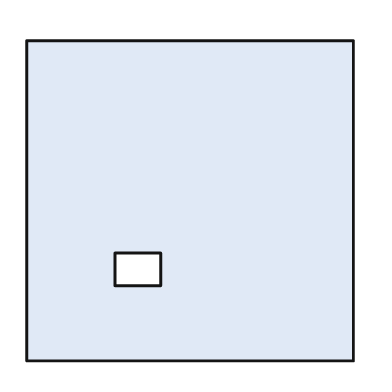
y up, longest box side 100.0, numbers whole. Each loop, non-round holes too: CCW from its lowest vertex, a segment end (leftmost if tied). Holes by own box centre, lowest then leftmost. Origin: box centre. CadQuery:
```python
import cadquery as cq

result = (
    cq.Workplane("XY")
    .moveTo(-50.0, -49.0)
    .lineTo(50.0, -49.0)
    .lineTo(50.0, 49.0)
    .lineTo(-50.0, 49.0)
    .close()
    .moveTo(-23.0, -26.0)
    .lineTo(-9.0, -26.0)
    .lineTo(-9.0, -16.0)
    .lineTo(-23.0, -16.0)
    .close()
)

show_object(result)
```